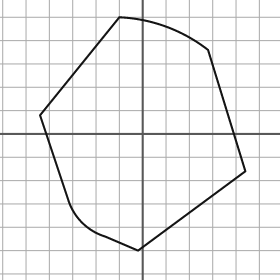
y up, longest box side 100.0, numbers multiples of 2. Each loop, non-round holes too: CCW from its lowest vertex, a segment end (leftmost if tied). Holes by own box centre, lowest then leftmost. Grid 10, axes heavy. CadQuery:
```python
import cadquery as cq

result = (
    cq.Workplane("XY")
    .moveTo(-2.0, -50.0)
    .lineTo(44.0, -16.0)
    .lineTo(28.0, 36.0)
    .threePointArc((10.0, 46.0), (-10.0, 50.0))
    .lineTo(-44.0, 8.0)
    .lineTo(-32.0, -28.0)
    .threePointArc((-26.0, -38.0), (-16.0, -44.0))
    .close()
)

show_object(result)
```